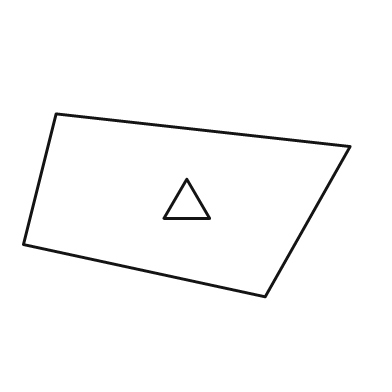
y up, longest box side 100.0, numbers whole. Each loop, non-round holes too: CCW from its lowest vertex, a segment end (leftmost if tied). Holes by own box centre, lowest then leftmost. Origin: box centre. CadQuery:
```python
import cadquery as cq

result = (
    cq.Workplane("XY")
    .moveTo(24.0, -28.0)
    .lineTo(50.0, 18.0)
    .lineTo(-40.0, 28.0)
    .lineTo(-50.0, -12.0)
    .close()
    .moveTo(-7.0, -4.0)
    .lineTo(7.0, -4.0)
    .lineTo(0.0, 8.0)
    .close()
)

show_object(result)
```